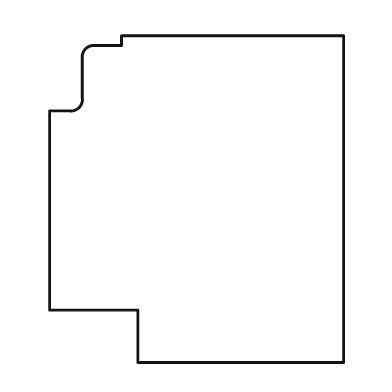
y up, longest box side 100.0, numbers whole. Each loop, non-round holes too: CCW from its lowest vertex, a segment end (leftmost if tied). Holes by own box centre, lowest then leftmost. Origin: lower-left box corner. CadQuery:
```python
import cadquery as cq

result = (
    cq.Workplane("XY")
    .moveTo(27.0, 0.0)
    .lineTo(90.0, 0.0)
    .lineTo(90.0, 100.0)
    .lineTo(22.0, 100.0)
    .lineTo(22.0, 97.0)
    .lineTo(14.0, 97.0)
    .threePointArc((11.0, 96.0), (10.0, 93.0))
    .lineTo(10.0, 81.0)
    .threePointArc((9.0, 78.0), (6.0, 77.0))
    .lineTo(0.0, 77.0)
    .lineTo(0.0, 16.0)
    .lineTo(27.0, 16.0)
    .close()
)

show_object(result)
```